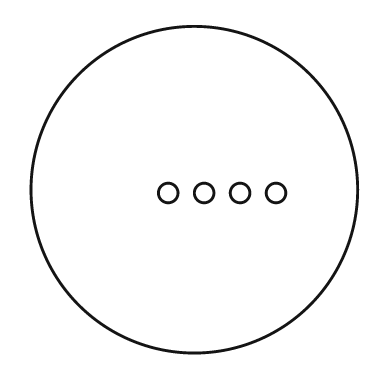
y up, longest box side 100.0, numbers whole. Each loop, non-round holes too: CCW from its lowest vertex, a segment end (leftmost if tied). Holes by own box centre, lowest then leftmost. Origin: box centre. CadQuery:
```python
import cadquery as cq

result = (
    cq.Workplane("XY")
    .moveTo(0.0, 0.0)
    .circle(50.0)
    .moveTo(-8.0, -1.0)
    .circle(3.0)
    .moveTo(3.0, -1.0)
    .circle(3.0)
    .moveTo(14.0, -1.0)
    .circle(3.0)
    .moveTo(25.0, -1.0)
    .circle(3.0)
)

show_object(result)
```